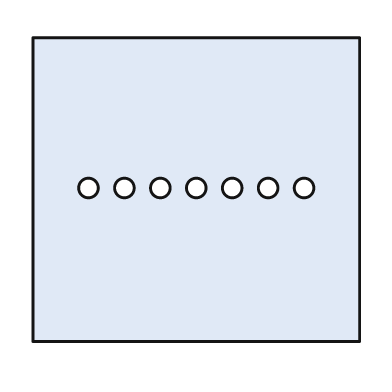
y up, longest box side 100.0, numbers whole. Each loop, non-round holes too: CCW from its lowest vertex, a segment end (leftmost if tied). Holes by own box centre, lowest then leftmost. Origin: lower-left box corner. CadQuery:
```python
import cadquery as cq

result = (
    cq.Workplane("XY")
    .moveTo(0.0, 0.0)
    .lineTo(100.0, 0.0)
    .lineTo(100.0, 93.0)
    .lineTo(0.0, 93.0)
    .close()
    .moveTo(17.0, 47.0)
    .circle(3.0)
    .moveTo(28.0, 47.0)
    .circle(3.0)
    .moveTo(39.0, 47.0)
    .circle(3.0)
    .moveTo(50.0, 47.0)
    .circle(3.0)
    .moveTo(61.0, 47.0)
    .circle(3.0)
    .moveTo(72.0, 47.0)
    .circle(3.0)
    .moveTo(83.0, 47.0)
    .circle(3.0)
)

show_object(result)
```